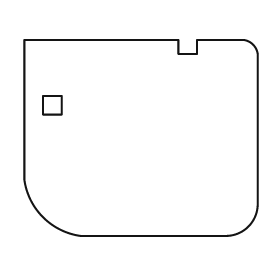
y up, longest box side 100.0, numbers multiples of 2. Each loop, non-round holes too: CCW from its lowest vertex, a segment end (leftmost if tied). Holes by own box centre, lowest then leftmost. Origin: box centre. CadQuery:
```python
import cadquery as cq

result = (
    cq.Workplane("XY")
    .moveTo(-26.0, -42.0)
    .lineTo(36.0, -42.0)
    .threePointArc((46.0, -38.0), (50.0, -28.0))
    .lineTo(50.0, 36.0)
    .threePointArc((48.0, 40.0), (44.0, 42.0))
    .lineTo(24.0, 42.0)
    .lineTo(24.0, 36.0)
    .lineTo(16.0, 36.0)
    .lineTo(16.0, 42.0)
    .lineTo(-50.0, 42.0)
    .lineTo(-50.0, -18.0)
    .threePointArc((-42.0, -34.0), (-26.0, -42.0))
    .close()
    .moveTo(-42.0, 10.0)
    .lineTo(-34.0, 10.0)
    .lineTo(-34.0, 18.0)
    .lineTo(-42.0, 18.0)
    .close()
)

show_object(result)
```